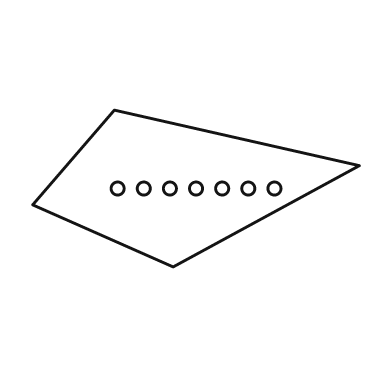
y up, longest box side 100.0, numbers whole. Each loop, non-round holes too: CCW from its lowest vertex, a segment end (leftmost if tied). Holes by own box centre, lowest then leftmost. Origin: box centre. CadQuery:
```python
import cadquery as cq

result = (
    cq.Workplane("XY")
    .moveTo(-7.0, -24.0)
    .lineTo(50.0, 7.0)
    .lineTo(-25.0, 24.0)
    .lineTo(-50.0, -5.0)
    .close()
    .moveTo(-24.0, 0.0)
    .circle(2.0)
    .moveTo(-16.0, 0.0)
    .circle(2.0)
    .moveTo(-8.0, 0.0)
    .circle(2.0)
    .moveTo(0.0, 0.0)
    .circle(2.0)
    .moveTo(8.0, 0.0)
    .circle(2.0)
    .moveTo(16.0, 0.0)
    .circle(2.0)
    .moveTo(24.0, 0.0)
    .circle(2.0)
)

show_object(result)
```